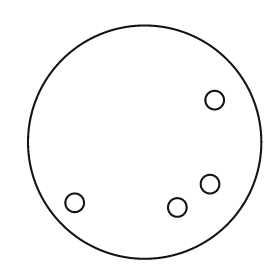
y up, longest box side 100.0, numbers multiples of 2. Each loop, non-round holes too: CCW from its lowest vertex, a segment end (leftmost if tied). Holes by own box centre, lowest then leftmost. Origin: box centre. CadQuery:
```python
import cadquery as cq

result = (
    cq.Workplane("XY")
    .moveTo(0.0, 0.0)
    .circle(50.0)
    .moveTo(14.0, -28.0)
    .circle(4.0)
    .moveTo(-30.0, -26.0)
    .circle(4.0)
    .moveTo(28.0, -18.0)
    .circle(4.0)
    .moveTo(30.0, 18.0)
    .circle(4.0)
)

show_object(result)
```